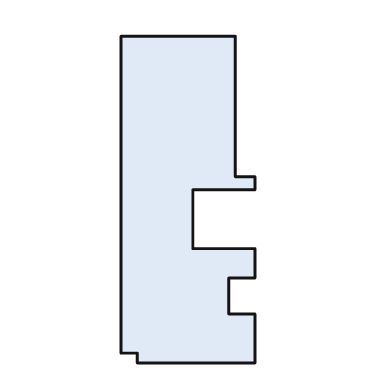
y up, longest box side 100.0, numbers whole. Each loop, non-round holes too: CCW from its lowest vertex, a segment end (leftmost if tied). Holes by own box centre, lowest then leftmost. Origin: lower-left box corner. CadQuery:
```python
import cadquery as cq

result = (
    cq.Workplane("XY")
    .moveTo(5.0, 0.0)
    .lineTo(41.0, 0.0)
    .lineTo(41.0, 15.0)
    .lineTo(33.0, 15.0)
    .lineTo(33.0, 26.0)
    .lineTo(41.0, 26.0)
    .lineTo(41.0, 35.0)
    .lineTo(22.0, 35.0)
    .lineTo(22.0, 53.0)
    .lineTo(41.0, 53.0)
    .lineTo(41.0, 57.0)
    .lineTo(35.0, 57.0)
    .lineTo(35.0, 100.0)
    .lineTo(0.0, 100.0)
    .lineTo(0.0, 3.0)
    .lineTo(5.0, 3.0)
    .close()
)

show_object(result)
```